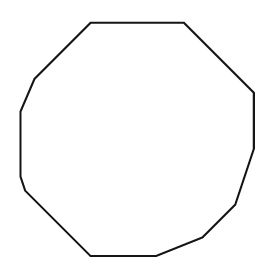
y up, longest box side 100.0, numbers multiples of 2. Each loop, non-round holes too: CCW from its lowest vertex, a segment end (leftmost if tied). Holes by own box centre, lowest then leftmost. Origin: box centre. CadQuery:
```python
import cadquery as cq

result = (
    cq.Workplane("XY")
    .moveTo(-20.0, -50.0)
    .lineTo(8.0, -50.0)
    .lineTo(28.0, -42.0)
    .lineTo(42.0, -28.0)
    .lineTo(50.0, -4.0)
    .lineTo(50.0, 20.0)
    .lineTo(20.0, 50.0)
    .lineTo(-20.0, 50.0)
    .lineTo(-44.0, 26.0)
    .lineTo(-50.0, 12.0)
    .lineTo(-50.0, -16.0)
    .lineTo(-48.0, -22.0)
    .close()
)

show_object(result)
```